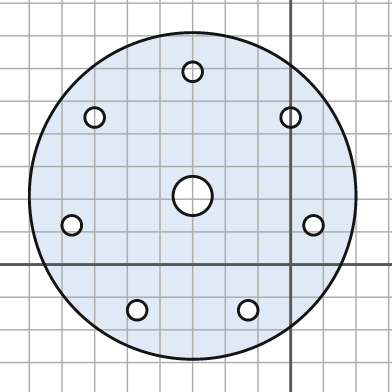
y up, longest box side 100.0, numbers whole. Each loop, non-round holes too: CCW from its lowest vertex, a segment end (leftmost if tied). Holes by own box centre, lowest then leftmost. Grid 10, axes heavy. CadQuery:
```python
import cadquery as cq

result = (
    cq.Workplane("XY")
    .moveTo(-30.0, 21.0)
    .circle(50.0)
    .moveTo(-47.0, -14.0)
    .circle(3.0)
    .moveTo(-13.0, -14.0)
    .circle(3.0)
    .moveTo(-67.0, 12.0)
    .circle(3.0)
    .moveTo(7.0, 12.0)
    .circle(3.0)
    .moveTo(-30.0, 21.0)
    .circle(6.0)
    .moveTo(-60.0, 45.0)
    .circle(3.0)
    .moveTo(0.0, 45.0)
    .circle(3.0)
    .moveTo(-30.0, 59.0)
    .circle(3.0)
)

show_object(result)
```